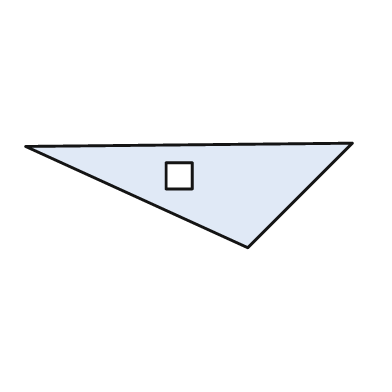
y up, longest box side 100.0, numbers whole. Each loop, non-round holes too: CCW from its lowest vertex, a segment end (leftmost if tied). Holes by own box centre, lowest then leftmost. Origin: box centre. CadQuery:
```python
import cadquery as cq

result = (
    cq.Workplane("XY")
    .moveTo(18.0, -16.0)
    .lineTo(50.0, 16.0)
    .lineTo(-50.0, 15.0)
    .close()
    .moveTo(-7.0, 2.0)
    .lineTo(1.0, 2.0)
    .lineTo(1.0, 10.0)
    .lineTo(-7.0, 10.0)
    .close()
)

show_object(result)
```